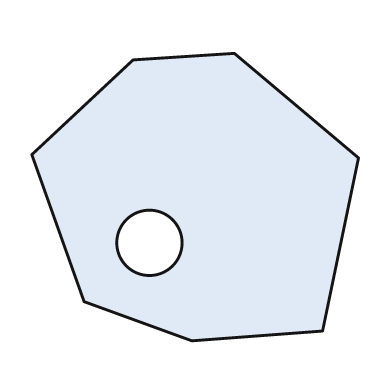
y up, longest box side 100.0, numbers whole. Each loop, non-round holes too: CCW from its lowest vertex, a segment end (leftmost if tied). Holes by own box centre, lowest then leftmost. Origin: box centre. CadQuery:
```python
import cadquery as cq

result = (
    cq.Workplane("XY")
    .moveTo(-1.0, -44.0)
    .lineTo(39.0, -41.0)
    .lineTo(50.0, 12.0)
    .lineTo(12.0, 44.0)
    .lineTo(-19.0, 42.0)
    .lineTo(-50.0, 13.0)
    .lineTo(-34.0, -32.0)
    .close()
    .moveTo(-14.0, -14.0)
    .circle(10.0)
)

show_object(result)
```